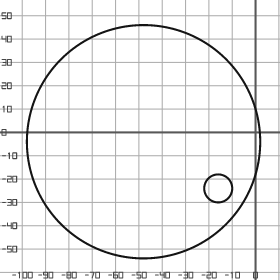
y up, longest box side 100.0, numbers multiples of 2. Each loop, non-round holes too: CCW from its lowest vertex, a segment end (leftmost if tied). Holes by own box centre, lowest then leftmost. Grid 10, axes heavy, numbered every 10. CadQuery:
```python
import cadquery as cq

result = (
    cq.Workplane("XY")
    .moveTo(-48.0, -4.0)
    .circle(50.0)
    .moveTo(-16.0, -24.0)
    .circle(6.0)
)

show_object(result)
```